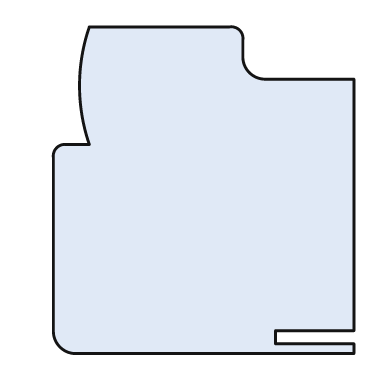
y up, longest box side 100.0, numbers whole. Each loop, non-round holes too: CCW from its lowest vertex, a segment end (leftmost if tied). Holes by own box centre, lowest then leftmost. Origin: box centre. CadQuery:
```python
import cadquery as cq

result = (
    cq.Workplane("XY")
    .moveTo(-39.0, -50.0)
    .lineTo(46.0, -50.0)
    .lineTo(46.0, -47.0)
    .lineTo(22.0, -47.0)
    .lineTo(22.0, -43.0)
    .lineTo(46.0, -43.0)
    .lineTo(46.0, 34.0)
    .lineTo(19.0, 34.0)
    .threePointArc((14.0, 36.0), (12.0, 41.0))
    .lineTo(12.0, 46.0)
    .threePointArc((11.0, 49.0), (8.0, 50.0))
    .lineTo(-35.0, 50.0)
    .threePointArc((-38.0, 32.0), (-35.0, 14.0))
    .lineTo(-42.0, 14.0)
    .threePointArc((-45.0, 13.0), (-46.0, 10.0))
    .lineTo(-46.0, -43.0)
    .threePointArc((-44.0, -48.0), (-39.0, -50.0))
    .close()
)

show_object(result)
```